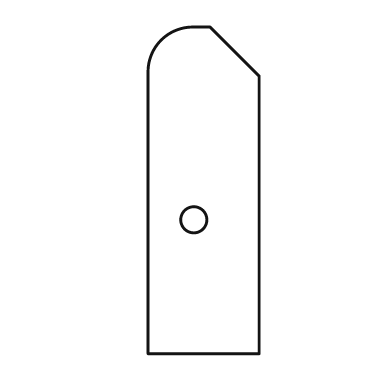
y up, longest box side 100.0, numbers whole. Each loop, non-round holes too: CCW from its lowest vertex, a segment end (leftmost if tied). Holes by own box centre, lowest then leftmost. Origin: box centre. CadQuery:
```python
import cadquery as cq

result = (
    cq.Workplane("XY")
    .moveTo(-17.0, -50.0)
    .lineTo(17.0, -50.0)
    .lineTo(17.0, 35.0)
    .lineTo(2.0, 50.0)
    .lineTo(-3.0, 50.0)
    .threePointArc((-13.0, 46.0), (-17.0, 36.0))
    .close()
    .moveTo(-3.0, -9.0)
    .circle(4.0)
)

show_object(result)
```